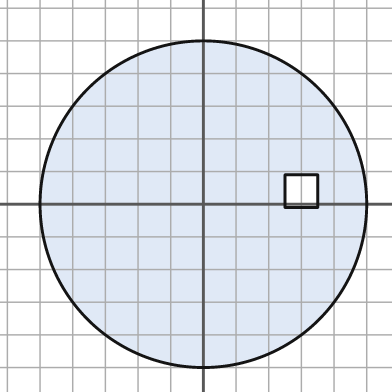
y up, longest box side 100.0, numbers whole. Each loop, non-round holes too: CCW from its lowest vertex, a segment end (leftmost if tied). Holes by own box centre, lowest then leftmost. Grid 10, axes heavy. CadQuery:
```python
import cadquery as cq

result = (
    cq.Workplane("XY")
    .moveTo(0.0, 0.0)
    .circle(50.0)
    .moveTo(25.0, -1.0)
    .lineTo(35.0, -1.0)
    .lineTo(35.0, 9.0)
    .lineTo(25.0, 9.0)
    .close()
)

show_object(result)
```